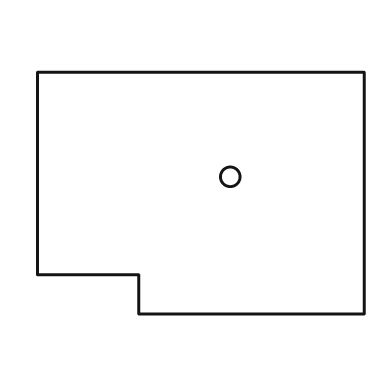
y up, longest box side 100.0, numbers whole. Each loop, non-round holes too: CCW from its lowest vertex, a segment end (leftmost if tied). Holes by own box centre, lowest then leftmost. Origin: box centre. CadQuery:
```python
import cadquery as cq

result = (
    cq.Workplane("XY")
    .moveTo(-19.0, -37.0)
    .lineTo(50.0, -37.0)
    .lineTo(50.0, 37.0)
    .lineTo(-50.0, 37.0)
    .lineTo(-50.0, -25.0)
    .lineTo(-19.0, -25.0)
    .close()
    .moveTo(9.0, 5.0)
    .circle(3.0)
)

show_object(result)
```